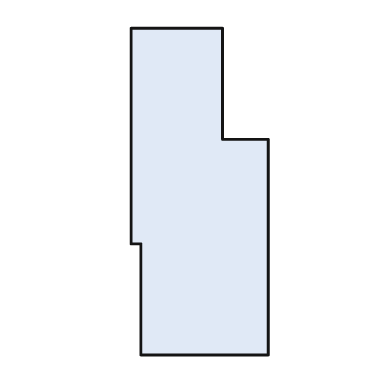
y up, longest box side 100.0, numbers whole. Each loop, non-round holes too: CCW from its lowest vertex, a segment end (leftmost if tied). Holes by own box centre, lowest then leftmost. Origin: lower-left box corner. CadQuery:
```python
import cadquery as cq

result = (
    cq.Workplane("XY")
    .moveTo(3.0, 0.0)
    .lineTo(42.0, 0.0)
    .lineTo(42.0, 66.0)
    .lineTo(28.0, 66.0)
    .lineTo(28.0, 100.0)
    .lineTo(0.0, 100.0)
    .lineTo(0.0, 34.0)
    .lineTo(3.0, 34.0)
    .close()
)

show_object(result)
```